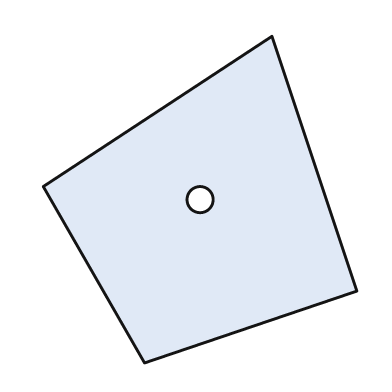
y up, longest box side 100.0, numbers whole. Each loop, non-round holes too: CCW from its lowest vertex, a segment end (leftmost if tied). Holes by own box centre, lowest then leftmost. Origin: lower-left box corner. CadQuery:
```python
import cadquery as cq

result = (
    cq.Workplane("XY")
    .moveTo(31.0, 0.0)
    .lineTo(96.0, 22.0)
    .lineTo(70.0, 100.0)
    .lineTo(0.0, 54.0)
    .close()
    .moveTo(48.0, 50.0)
    .circle(4.0)
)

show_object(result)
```